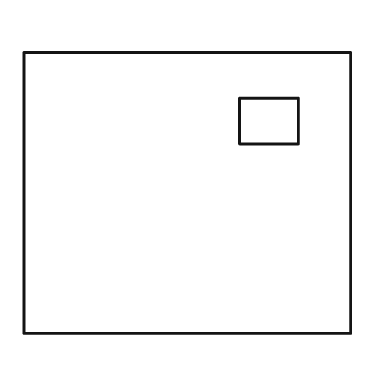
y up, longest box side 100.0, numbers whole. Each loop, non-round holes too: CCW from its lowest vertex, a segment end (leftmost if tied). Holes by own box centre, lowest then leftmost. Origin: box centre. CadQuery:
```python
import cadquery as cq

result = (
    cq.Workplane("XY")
    .moveTo(-50.0, -43.0)
    .lineTo(50.0, -43.0)
    .lineTo(50.0, 43.0)
    .lineTo(-50.0, 43.0)
    .close()
    .moveTo(16.0, 15.0)
    .lineTo(34.0, 15.0)
    .lineTo(34.0, 29.0)
    .lineTo(16.0, 29.0)
    .close()
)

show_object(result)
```